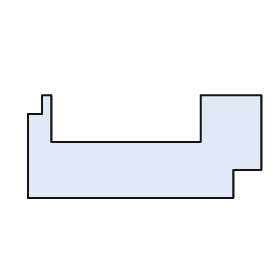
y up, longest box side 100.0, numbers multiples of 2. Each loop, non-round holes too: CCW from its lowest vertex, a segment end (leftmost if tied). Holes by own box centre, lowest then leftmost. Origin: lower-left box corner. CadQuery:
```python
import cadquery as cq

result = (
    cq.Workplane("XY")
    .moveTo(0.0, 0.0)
    .lineTo(88.0, 0.0)
    .lineTo(88.0, 12.0)
    .lineTo(100.0, 12.0)
    .lineTo(100.0, 44.0)
    .lineTo(74.0, 44.0)
    .lineTo(74.0, 24.0)
    .lineTo(10.0, 24.0)
    .lineTo(10.0, 44.0)
    .lineTo(6.0, 44.0)
    .lineTo(6.0, 36.0)
    .lineTo(0.0, 36.0)
    .close()
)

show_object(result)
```